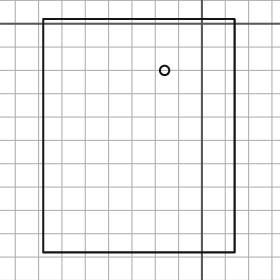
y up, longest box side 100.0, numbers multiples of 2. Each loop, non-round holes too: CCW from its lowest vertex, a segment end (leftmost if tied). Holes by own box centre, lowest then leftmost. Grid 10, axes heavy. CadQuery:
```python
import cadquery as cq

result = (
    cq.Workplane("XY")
    .moveTo(-68.0, -98.0)
    .lineTo(14.0, -98.0)
    .lineTo(14.0, 2.0)
    .lineTo(-68.0, 2.0)
    .close()
    .moveTo(-16.0, -20.0)
    .circle(2.0)
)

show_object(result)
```